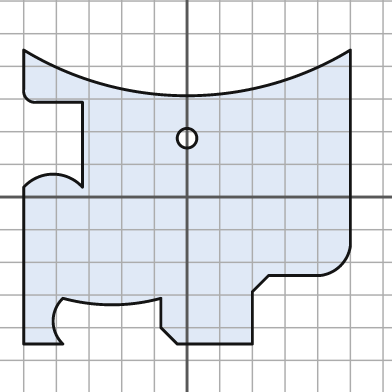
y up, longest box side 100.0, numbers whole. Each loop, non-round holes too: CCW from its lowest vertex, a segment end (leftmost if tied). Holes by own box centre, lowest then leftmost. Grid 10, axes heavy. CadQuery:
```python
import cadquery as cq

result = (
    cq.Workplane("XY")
    .moveTo(-50.0, -45.0)
    .lineTo(-38.0, -45.0)
    .threePointArc((-41.0, -38.0), (-38.0, -31.0))
    .threePointArc((-23.0, -33.0), (-8.0, -31.0))
    .lineTo(-8.0, -40.0)
    .lineTo(-3.0, -45.0)
    .lineTo(20.0, -45.0)
    .lineTo(20.0, -29.0)
    .lineTo(25.0, -24.0)
    .lineTo(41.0, -24.0)
    .threePointArc((47.0, -21.0), (50.0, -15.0))
    .lineTo(50.0, 45.0)
    .threePointArc((0.0, 31.0), (-50.0, 45.0))
    .lineTo(-50.0, 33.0)
    .threePointArc((-49.0, 30.0), (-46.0, 29.0))
    .lineTo(-32.0, 29.0)
    .lineTo(-32.0, 3.0)
    .threePointArc((-41.0, 7.0), (-50.0, 3.0))
    .close()
    .moveTo(0.0, 18.0)
    .circle(3.0)
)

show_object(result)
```